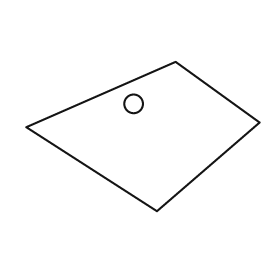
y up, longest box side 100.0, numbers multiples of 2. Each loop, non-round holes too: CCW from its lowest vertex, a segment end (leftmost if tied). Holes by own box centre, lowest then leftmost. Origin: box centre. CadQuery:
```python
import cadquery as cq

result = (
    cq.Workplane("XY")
    .moveTo(6.0, -32.0)
    .lineTo(50.0, 6.0)
    .lineTo(14.0, 32.0)
    .lineTo(-50.0, 4.0)
    .close()
    .moveTo(-4.0, 14.0)
    .circle(4.0)
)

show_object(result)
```